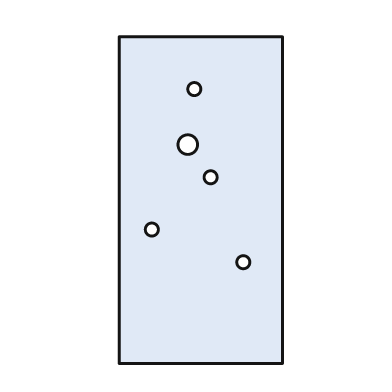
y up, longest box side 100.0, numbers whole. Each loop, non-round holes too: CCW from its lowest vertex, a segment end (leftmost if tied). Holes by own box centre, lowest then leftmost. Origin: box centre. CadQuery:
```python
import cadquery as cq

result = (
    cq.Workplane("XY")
    .moveTo(-25.0, -50.0)
    .lineTo(25.0, -50.0)
    .lineTo(25.0, 50.0)
    .lineTo(-25.0, 50.0)
    .close()
    .moveTo(13.0, -19.0)
    .circle(2.0)
    .moveTo(-15.0, -9.0)
    .circle(2.0)
    .moveTo(3.0, 7.0)
    .circle(2.0)
    .moveTo(-4.0, 17.0)
    .circle(3.0)
    .moveTo(-2.0, 34.0)
    .circle(2.0)
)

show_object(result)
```